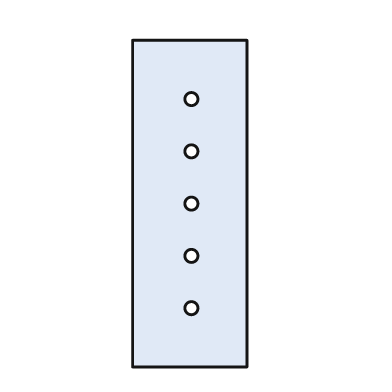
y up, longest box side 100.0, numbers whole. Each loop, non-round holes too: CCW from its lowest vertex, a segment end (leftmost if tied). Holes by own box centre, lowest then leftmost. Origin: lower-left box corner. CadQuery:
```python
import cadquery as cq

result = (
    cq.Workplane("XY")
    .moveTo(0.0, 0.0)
    .lineTo(35.0, 0.0)
    .lineTo(35.0, 100.0)
    .lineTo(0.0, 100.0)
    .close()
    .moveTo(18.0, 18.0)
    .circle(2.0)
    .moveTo(18.0, 34.0)
    .circle(2.0)
    .moveTo(18.0, 50.0)
    .circle(2.0)
    .moveTo(18.0, 66.0)
    .circle(2.0)
    .moveTo(18.0, 82.0)
    .circle(2.0)
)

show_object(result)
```